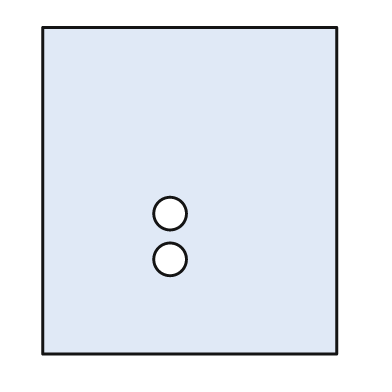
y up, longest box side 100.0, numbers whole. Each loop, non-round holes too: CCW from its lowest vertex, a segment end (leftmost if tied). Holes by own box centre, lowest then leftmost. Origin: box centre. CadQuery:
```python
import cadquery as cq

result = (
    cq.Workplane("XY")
    .moveTo(-45.0, -50.0)
    .lineTo(45.0, -50.0)
    .lineTo(45.0, 50.0)
    .lineTo(-45.0, 50.0)
    .close()
    .moveTo(-6.0, -21.0)
    .circle(5.0)
    .moveTo(-6.0, -7.0)
    .circle(5.0)
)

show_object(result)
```